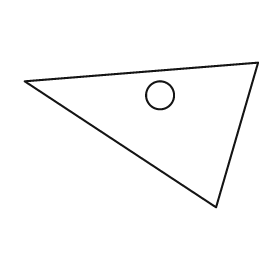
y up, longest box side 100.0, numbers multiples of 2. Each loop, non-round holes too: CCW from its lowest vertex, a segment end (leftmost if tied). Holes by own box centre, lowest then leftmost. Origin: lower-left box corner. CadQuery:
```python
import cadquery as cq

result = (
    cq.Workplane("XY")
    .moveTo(82.0, 0.0)
    .lineTo(100.0, 62.0)
    .lineTo(0.0, 54.0)
    .close()
    .moveTo(58.0, 48.0)
    .circle(6.0)
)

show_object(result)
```